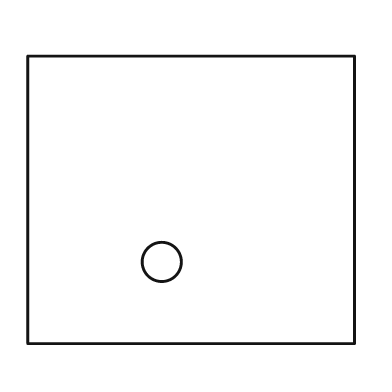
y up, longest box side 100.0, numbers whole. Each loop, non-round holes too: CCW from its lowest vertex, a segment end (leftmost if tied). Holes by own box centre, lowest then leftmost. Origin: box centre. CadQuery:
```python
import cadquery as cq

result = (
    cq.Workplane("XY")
    .moveTo(-50.0, -44.0)
    .lineTo(50.0, -44.0)
    .lineTo(50.0, 44.0)
    .lineTo(-50.0, 44.0)
    .close()
    .moveTo(-9.0, -19.0)
    .circle(6.0)
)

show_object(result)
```